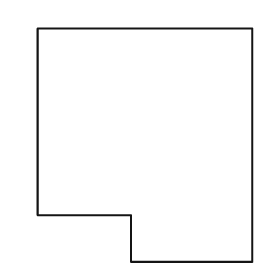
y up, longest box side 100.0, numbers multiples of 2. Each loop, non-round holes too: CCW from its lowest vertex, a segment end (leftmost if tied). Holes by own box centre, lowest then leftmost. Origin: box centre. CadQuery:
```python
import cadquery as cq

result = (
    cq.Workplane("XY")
    .moveTo(-6.0, -50.0)
    .lineTo(46.0, -50.0)
    .lineTo(46.0, 50.0)
    .lineTo(-46.0, 50.0)
    .lineTo(-46.0, -30.0)
    .lineTo(-6.0, -30.0)
    .close()
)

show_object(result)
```